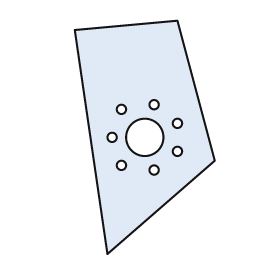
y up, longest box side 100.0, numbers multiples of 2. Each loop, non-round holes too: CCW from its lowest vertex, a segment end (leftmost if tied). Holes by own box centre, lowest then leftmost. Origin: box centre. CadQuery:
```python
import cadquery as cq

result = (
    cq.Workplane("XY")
    .moveTo(-16.0, -50.0)
    .lineTo(30.0, -10.0)
    .lineTo(14.0, 50.0)
    .lineTo(-30.0, 46.0)
    .close()
    .moveTo(4.0, -14.0)
    .circle(2.0)
    .moveTo(-10.0, -12.0)
    .circle(2.0)
    .moveTo(14.0, -6.0)
    .circle(2.0)
    .moveTo(-14.0, 0.0)
    .circle(2.0)
    .moveTo(0.0, 0.0)
    .circle(8.0)
    .moveTo(14.0, 6.0)
    .circle(2.0)
    .moveTo(-10.0, 12.0)
    .circle(2.0)
    .moveTo(4.0, 14.0)
    .circle(2.0)
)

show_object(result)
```